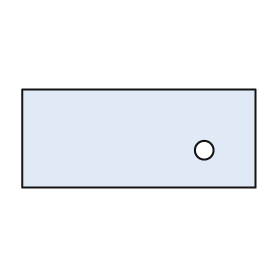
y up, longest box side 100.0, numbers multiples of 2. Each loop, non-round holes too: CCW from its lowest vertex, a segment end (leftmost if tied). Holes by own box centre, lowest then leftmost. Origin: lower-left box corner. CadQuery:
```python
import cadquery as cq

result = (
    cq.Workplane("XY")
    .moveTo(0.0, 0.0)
    .lineTo(100.0, 0.0)
    .lineTo(100.0, 42.0)
    .lineTo(0.0, 42.0)
    .close()
    .moveTo(78.0, 16.0)
    .circle(4.0)
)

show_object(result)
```